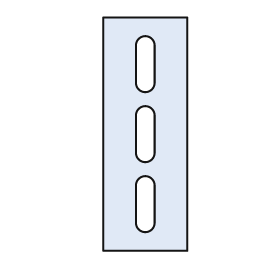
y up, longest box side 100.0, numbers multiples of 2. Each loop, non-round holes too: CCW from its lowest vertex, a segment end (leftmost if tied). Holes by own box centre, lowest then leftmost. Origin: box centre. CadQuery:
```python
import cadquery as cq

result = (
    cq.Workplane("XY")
    .moveTo(-18.0, -50.0)
    .lineTo(18.0, -50.0)
    .lineTo(18.0, 50.0)
    .lineTo(-18.0, 50.0)
    .close()
    .moveTo(-4.0, -38.0)
    .threePointArc((0.0, -42.0), (4.0, -38.0))
    .lineTo(4.0, -22.0)
    .threePointArc((0.0, -18.0), (-4.0, -22.0))
    .close()
    .moveTo(-4.0, -8.0)
    .threePointArc((0.0, -12.0), (4.0, -8.0))
    .lineTo(4.0, 8.0)
    .threePointArc((0.0, 12.0), (-4.0, 8.0))
    .close()
    .moveTo(-4.0, 22.0)
    .threePointArc((0.0, 18.0), (4.0, 22.0))
    .lineTo(4.0, 38.0)
    .threePointArc((0.0, 42.0), (-4.0, 38.0))
    .close()
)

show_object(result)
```